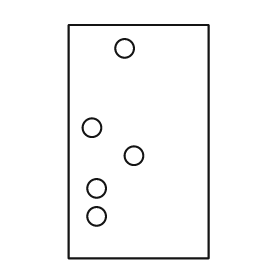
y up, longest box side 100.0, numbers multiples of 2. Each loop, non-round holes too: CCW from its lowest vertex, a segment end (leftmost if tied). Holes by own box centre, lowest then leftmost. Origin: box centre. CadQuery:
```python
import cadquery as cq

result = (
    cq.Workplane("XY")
    .moveTo(-30.0, -50.0)
    .lineTo(30.0, -50.0)
    .lineTo(30.0, 50.0)
    .lineTo(-30.0, 50.0)
    .close()
    .moveTo(-18.0, -32.0)
    .circle(4.0)
    .moveTo(-18.0, -20.0)
    .circle(4.0)
    .moveTo(-2.0, -6.0)
    .circle(4.0)
    .moveTo(-20.0, 6.0)
    .circle(4.0)
    .moveTo(-6.0, 40.0)
    .circle(4.0)
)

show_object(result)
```